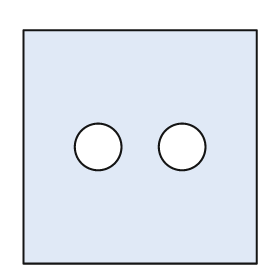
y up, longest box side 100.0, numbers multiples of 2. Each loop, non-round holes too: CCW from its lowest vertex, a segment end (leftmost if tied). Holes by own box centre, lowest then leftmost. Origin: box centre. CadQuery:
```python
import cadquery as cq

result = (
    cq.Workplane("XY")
    .moveTo(-50.0, -50.0)
    .lineTo(50.0, -50.0)
    .lineTo(50.0, 50.0)
    .lineTo(-50.0, 50.0)
    .close()
    .moveTo(-18.0, 0.0)
    .circle(10.0)
    .moveTo(18.0, 0.0)
    .circle(10.0)
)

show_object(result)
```